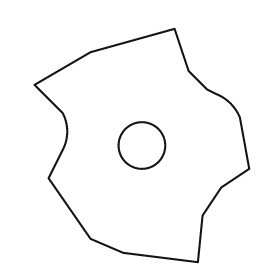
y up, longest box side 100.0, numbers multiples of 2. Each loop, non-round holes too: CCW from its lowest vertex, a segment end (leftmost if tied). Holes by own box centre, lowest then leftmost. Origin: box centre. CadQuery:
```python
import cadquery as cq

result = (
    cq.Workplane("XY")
    .moveTo(24.0, -50.0)
    .lineTo(26.0, -30.0)
    .lineTo(34.0, -18.0)
    .lineTo(46.0, -10.0)
    .lineTo(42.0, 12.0)
    .threePointArc((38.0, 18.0), (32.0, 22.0))
    .lineTo(28.0, 24.0)
    .lineTo(20.0, 32.0)
    .lineTo(14.0, 50.0)
    .lineTo(-22.0, 40.0)
    .lineTo(-46.0, 26.0)
    .lineTo(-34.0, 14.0)
    .threePointArc((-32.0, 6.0), (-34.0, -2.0))
    .lineTo(-40.0, -14.0)
    .lineTo(-22.0, -40.0)
    .lineTo(-8.0, -46.0)
    .close()
    .moveTo(0.0, 0.0)
    .circle(10.0)
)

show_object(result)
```